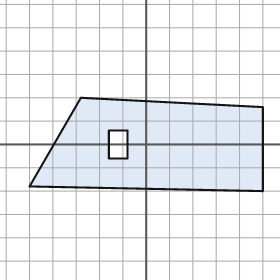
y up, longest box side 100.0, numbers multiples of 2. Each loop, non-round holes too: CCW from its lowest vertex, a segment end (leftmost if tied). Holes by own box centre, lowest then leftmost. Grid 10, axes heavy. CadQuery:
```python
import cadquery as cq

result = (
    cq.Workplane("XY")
    .moveTo(50.0, -20.0)
    .lineTo(50.0, 16.0)
    .lineTo(-28.0, 20.0)
    .lineTo(-50.0, -18.0)
    .close()
    .moveTo(-16.0, -6.0)
    .lineTo(-8.0, -6.0)
    .lineTo(-8.0, 6.0)
    .lineTo(-16.0, 6.0)
    .close()
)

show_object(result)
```